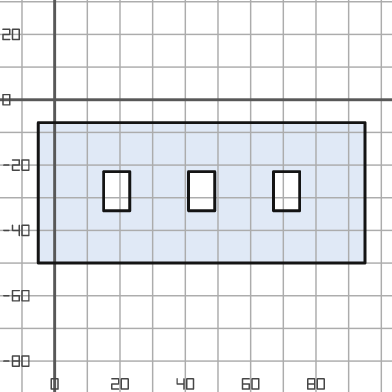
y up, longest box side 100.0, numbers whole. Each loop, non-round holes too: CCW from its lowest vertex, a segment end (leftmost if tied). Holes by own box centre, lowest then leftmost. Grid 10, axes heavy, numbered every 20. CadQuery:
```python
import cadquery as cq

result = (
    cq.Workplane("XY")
    .moveTo(-5.0, -50.0)
    .lineTo(95.0, -50.0)
    .lineTo(95.0, -7.0)
    .lineTo(-5.0, -7.0)
    .close()
    .moveTo(15.0, -34.0)
    .lineTo(23.0, -34.0)
    .lineTo(23.0, -22.0)
    .lineTo(15.0, -22.0)
    .close()
    .moveTo(41.0, -34.0)
    .lineTo(49.0, -34.0)
    .lineTo(49.0, -22.0)
    .lineTo(41.0, -22.0)
    .close()
    .moveTo(67.0, -34.0)
    .lineTo(75.0, -34.0)
    .lineTo(75.0, -22.0)
    .lineTo(67.0, -22.0)
    .close()
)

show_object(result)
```